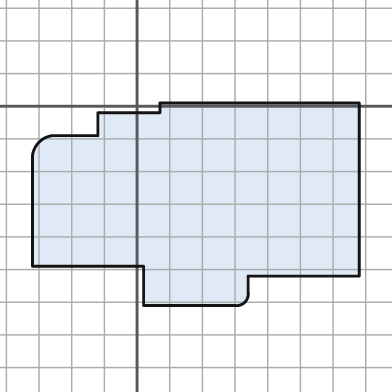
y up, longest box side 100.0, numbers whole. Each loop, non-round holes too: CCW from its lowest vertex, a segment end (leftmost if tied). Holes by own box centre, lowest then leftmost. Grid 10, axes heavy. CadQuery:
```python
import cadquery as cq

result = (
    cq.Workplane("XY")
    .moveTo(2.0, -61.0)
    .lineTo(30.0, -61.0)
    .threePointArc((33.0, -60.0), (34.0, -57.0))
    .lineTo(34.0, -52.0)
    .lineTo(68.0, -52.0)
    .lineTo(68.0, 1.0)
    .lineTo(7.0, 1.0)
    .lineTo(7.0, -2.0)
    .lineTo(-12.0, -2.0)
    .lineTo(-12.0, -9.0)
    .lineTo(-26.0, -9.0)
    .threePointArc((-30.0, -11.0), (-32.0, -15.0))
    .lineTo(-32.0, -49.0)
    .lineTo(2.0, -49.0)
    .close()
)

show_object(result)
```